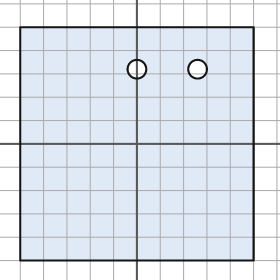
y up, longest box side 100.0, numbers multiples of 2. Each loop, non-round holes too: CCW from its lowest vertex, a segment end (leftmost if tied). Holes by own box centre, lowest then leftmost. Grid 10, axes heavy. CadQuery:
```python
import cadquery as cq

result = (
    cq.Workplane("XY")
    .moveTo(-50.0, -50.0)
    .lineTo(50.0, -50.0)
    .lineTo(50.0, 50.0)
    .lineTo(-50.0, 50.0)
    .close()
    .moveTo(0.0, 32.0)
    .circle(4.0)
    .moveTo(26.0, 32.0)
    .circle(4.0)
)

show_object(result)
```